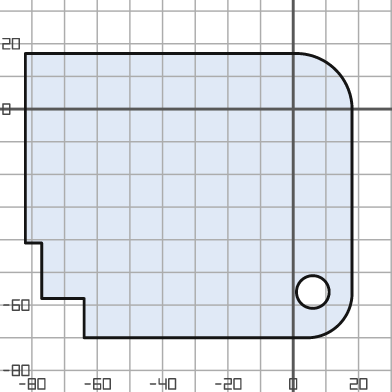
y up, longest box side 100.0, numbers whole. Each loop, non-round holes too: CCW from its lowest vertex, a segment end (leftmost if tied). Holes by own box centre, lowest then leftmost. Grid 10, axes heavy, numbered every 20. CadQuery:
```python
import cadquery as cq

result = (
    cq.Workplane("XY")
    .moveTo(-64.0, -70.0)
    .lineTo(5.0, -70.0)
    .threePointArc((14.0, -66.0), (18.0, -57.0))
    .lineTo(18.0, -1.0)
    .threePointArc((13.0, 12.0), (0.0, 17.0))
    .lineTo(-82.0, 17.0)
    .lineTo(-82.0, -41.0)
    .lineTo(-77.0, -41.0)
    .lineTo(-77.0, -58.0)
    .lineTo(-64.0, -58.0)
    .close()
    .moveTo(6.0, -56.0)
    .circle(5.0)
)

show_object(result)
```